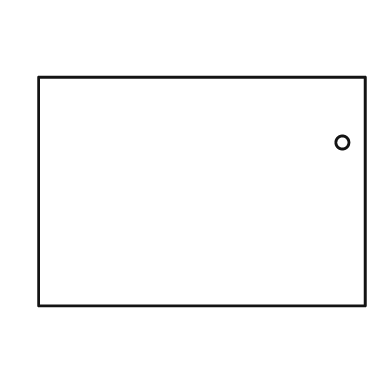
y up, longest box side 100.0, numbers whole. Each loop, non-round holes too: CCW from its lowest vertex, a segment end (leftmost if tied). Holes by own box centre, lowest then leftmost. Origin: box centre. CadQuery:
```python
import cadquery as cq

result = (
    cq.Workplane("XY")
    .moveTo(-50.0, -35.0)
    .lineTo(50.0, -35.0)
    .lineTo(50.0, 35.0)
    .lineTo(-50.0, 35.0)
    .close()
    .moveTo(43.0, 15.0)
    .circle(2.0)
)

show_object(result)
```